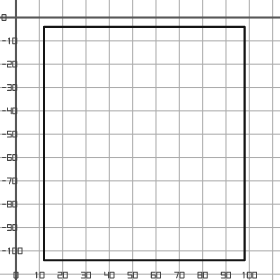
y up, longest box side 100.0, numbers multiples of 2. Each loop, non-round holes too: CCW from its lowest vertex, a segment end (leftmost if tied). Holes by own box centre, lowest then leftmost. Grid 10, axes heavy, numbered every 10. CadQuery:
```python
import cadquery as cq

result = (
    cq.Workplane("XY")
    .moveTo(12.0, -104.0)
    .lineTo(98.0, -104.0)
    .lineTo(98.0, -4.0)
    .lineTo(12.0, -4.0)
    .close()
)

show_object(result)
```